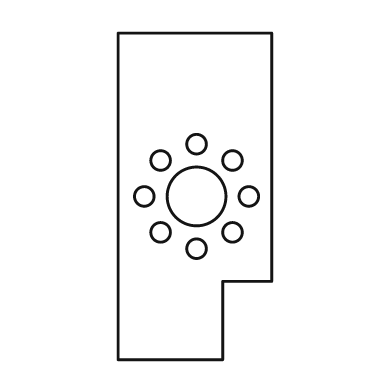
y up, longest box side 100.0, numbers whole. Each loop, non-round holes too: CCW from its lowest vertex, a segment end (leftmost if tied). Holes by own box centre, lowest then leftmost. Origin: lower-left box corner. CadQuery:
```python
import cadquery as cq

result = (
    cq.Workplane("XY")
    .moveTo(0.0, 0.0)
    .lineTo(32.0, 0.0)
    .lineTo(32.0, 24.0)
    .lineTo(47.0, 24.0)
    .lineTo(47.0, 100.0)
    .lineTo(0.0, 100.0)
    .close()
    .moveTo(24.0, 34.0)
    .circle(3.0)
    .moveTo(13.0, 39.0)
    .circle(3.0)
    .moveTo(35.0, 39.0)
    .circle(3.0)
    .moveTo(8.0, 50.0)
    .circle(3.0)
    .moveTo(24.0, 50.0)
    .circle(9.0)
    .moveTo(40.0, 50.0)
    .circle(3.0)
    .moveTo(13.0, 61.0)
    .circle(3.0)
    .moveTo(35.0, 61.0)
    .circle(3.0)
    .moveTo(24.0, 66.0)
    .circle(3.0)
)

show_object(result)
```